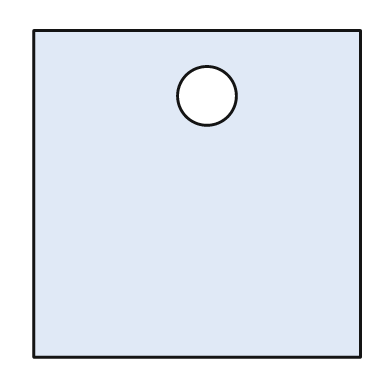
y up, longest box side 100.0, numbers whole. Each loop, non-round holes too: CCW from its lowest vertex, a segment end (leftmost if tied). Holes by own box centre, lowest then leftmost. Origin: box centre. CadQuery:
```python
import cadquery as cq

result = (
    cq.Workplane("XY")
    .moveTo(-50.0, -50.0)
    .lineTo(50.0, -50.0)
    .lineTo(50.0, 50.0)
    .lineTo(-50.0, 50.0)
    .close()
    .moveTo(3.0, 30.0)
    .circle(9.0)
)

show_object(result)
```